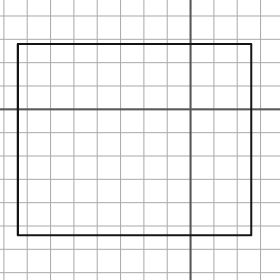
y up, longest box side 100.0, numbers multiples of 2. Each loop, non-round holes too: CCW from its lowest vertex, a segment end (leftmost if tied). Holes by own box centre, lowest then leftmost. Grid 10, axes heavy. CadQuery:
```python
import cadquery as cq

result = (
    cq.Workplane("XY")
    .moveTo(-74.0, -54.0)
    .lineTo(26.0, -54.0)
    .lineTo(26.0, 28.0)
    .lineTo(-74.0, 28.0)
    .close()
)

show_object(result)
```